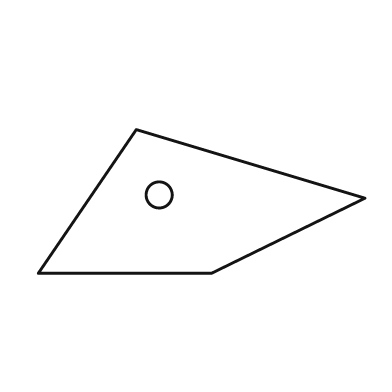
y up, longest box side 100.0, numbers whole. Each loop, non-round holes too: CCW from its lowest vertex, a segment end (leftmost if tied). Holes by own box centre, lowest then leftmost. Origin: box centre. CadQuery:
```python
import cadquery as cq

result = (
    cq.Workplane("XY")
    .moveTo(-50.0, -22.0)
    .lineTo(3.0, -22.0)
    .lineTo(50.0, 1.0)
    .lineTo(-20.0, 22.0)
    .close()
    .moveTo(-13.0, 2.0)
    .circle(4.0)
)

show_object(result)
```